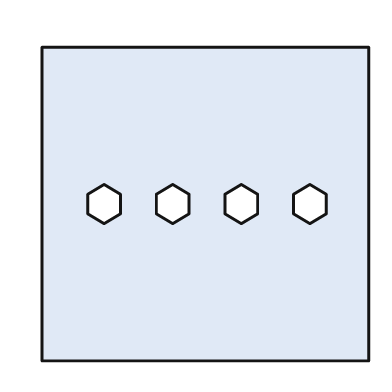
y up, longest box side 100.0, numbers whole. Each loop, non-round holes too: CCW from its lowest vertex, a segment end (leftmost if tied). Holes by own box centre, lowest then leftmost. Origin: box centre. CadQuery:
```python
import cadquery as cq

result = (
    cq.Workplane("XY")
    .moveTo(-50.0, -48.0)
    .lineTo(50.0, -48.0)
    .lineTo(50.0, 48.0)
    .lineTo(-50.0, 48.0)
    .close()
    .moveTo(-31.0, -6.0)
    .lineTo(-26.0, -3.0)
    .lineTo(-26.0, 3.0)
    .lineTo(-31.0, 6.0)
    .lineTo(-36.0, 3.0)
    .lineTo(-36.0, -3.0)
    .close()
    .moveTo(-10.0, -6.0)
    .lineTo(-5.0, -3.0)
    .lineTo(-5.0, 3.0)
    .lineTo(-10.0, 6.0)
    .lineTo(-15.0, 3.0)
    .lineTo(-15.0, -3.0)
    .close()
    .moveTo(11.0, -6.0)
    .lineTo(16.0, -3.0)
    .lineTo(16.0, 3.0)
    .lineTo(11.0, 6.0)
    .lineTo(6.0, 3.0)
    .lineTo(6.0, -3.0)
    .close()
    .moveTo(32.0, -6.0)
    .lineTo(37.0, -3.0)
    .lineTo(37.0, 3.0)
    .lineTo(32.0, 6.0)
    .lineTo(27.0, 3.0)
    .lineTo(27.0, -3.0)
    .close()
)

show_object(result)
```